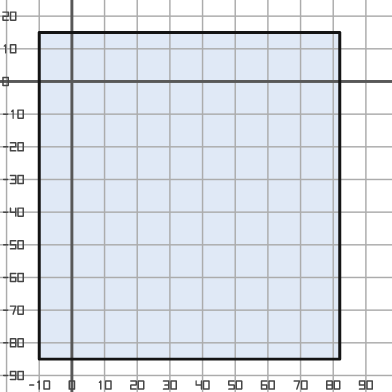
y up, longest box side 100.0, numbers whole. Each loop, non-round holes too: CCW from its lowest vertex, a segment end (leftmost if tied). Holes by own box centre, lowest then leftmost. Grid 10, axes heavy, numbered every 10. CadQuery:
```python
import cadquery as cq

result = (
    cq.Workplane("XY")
    .moveTo(-10.0, -85.0)
    .lineTo(82.0, -85.0)
    .lineTo(82.0, 15.0)
    .lineTo(-10.0, 15.0)
    .close()
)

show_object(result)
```